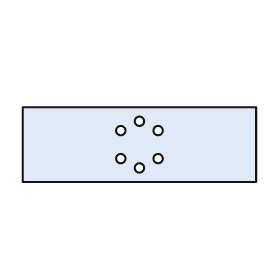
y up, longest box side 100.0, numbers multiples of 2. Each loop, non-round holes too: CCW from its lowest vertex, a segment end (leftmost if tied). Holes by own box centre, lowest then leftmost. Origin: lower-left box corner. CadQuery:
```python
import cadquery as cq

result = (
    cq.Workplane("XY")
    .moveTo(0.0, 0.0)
    .lineTo(100.0, 0.0)
    .lineTo(100.0, 32.0)
    .lineTo(0.0, 32.0)
    .close()
    .moveTo(50.0, 6.0)
    .circle(2.0)
    .moveTo(42.0, 10.0)
    .circle(2.0)
    .moveTo(58.0, 10.0)
    .circle(2.0)
    .moveTo(42.0, 22.0)
    .circle(2.0)
    .moveTo(58.0, 22.0)
    .circle(2.0)
    .moveTo(50.0, 26.0)
    .circle(2.0)
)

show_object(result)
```